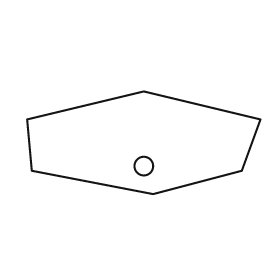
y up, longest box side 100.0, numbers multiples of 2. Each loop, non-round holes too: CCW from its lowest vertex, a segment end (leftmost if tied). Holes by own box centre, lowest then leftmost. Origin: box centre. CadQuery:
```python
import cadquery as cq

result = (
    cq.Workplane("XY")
    .moveTo(4.0, -22.0)
    .lineTo(42.0, -12.0)
    .lineTo(50.0, 10.0)
    .lineTo(0.0, 22.0)
    .lineTo(-50.0, 10.0)
    .lineTo(-48.0, -12.0)
    .close()
    .moveTo(0.0, -10.0)
    .circle(4.0)
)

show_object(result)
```